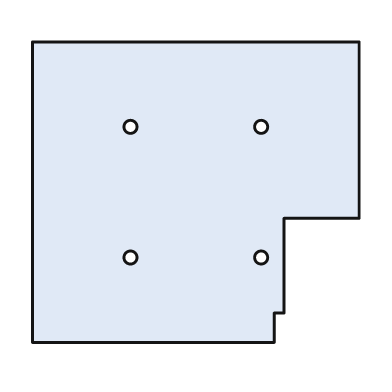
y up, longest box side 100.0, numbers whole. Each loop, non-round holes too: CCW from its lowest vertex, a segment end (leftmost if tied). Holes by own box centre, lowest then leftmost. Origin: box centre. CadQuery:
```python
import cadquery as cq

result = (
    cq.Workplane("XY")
    .moveTo(-50.0, -46.0)
    .lineTo(24.0, -46.0)
    .lineTo(24.0, -37.0)
    .lineTo(27.0, -37.0)
    .lineTo(27.0, -8.0)
    .lineTo(50.0, -8.0)
    .lineTo(50.0, 46.0)
    .lineTo(-50.0, 46.0)
    .close()
    .moveTo(-20.0, -20.0)
    .circle(2.0)
    .moveTo(20.0, -20.0)
    .circle(2.0)
    .moveTo(-20.0, 20.0)
    .circle(2.0)
    .moveTo(20.0, 20.0)
    .circle(2.0)
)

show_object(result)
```